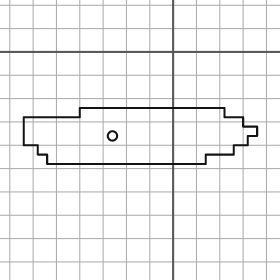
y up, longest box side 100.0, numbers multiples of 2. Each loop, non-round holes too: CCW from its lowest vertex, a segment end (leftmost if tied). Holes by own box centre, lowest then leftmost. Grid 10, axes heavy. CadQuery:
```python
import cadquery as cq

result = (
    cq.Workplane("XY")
    .moveTo(-54.0, -48.0)
    .lineTo(14.0, -48.0)
    .lineTo(14.0, -44.0)
    .lineTo(26.0, -44.0)
    .lineTo(26.0, -40.0)
    .lineTo(32.0, -40.0)
    .lineTo(32.0, -36.0)
    .lineTo(36.0, -36.0)
    .lineTo(36.0, -32.0)
    .lineTo(30.0, -32.0)
    .lineTo(30.0, -28.0)
    .lineTo(22.0, -28.0)
    .lineTo(22.0, -24.0)
    .lineTo(-40.0, -24.0)
    .lineTo(-40.0, -28.0)
    .lineTo(-64.0, -28.0)
    .lineTo(-64.0, -40.0)
    .lineTo(-58.0, -40.0)
    .lineTo(-58.0, -44.0)
    .lineTo(-54.0, -44.0)
    .close()
    .moveTo(-26.0, -36.0)
    .circle(2.0)
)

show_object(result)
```